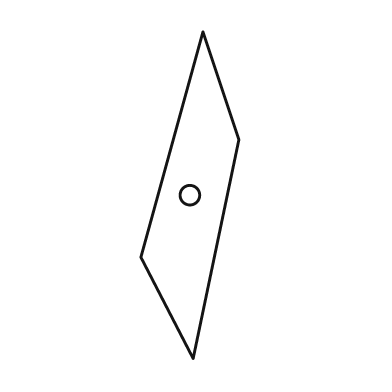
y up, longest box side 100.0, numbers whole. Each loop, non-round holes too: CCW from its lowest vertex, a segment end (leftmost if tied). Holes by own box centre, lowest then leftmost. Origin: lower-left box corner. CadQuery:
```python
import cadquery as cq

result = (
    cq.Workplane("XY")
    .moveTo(16.0, 0.0)
    .lineTo(30.0, 67.0)
    .lineTo(19.0, 100.0)
    .lineTo(0.0, 31.0)
    .close()
    .moveTo(15.0, 50.0)
    .circle(3.0)
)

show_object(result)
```